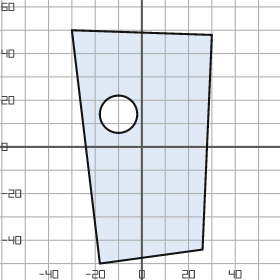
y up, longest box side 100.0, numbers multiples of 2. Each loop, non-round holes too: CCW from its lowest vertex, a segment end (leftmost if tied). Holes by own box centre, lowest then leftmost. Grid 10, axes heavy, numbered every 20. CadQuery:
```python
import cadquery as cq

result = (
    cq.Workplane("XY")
    .moveTo(-18.0, -50.0)
    .lineTo(26.0, -44.0)
    .lineTo(30.0, 48.0)
    .lineTo(-30.0, 50.0)
    .close()
    .moveTo(-10.0, 14.0)
    .circle(8.0)
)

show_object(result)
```